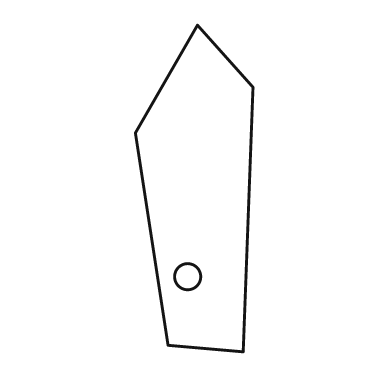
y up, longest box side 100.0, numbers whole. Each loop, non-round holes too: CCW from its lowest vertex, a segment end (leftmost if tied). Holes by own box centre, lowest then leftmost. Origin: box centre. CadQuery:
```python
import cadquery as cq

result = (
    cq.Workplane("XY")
    .moveTo(15.0, -50.0)
    .lineTo(18.0, 31.0)
    .lineTo(1.0, 50.0)
    .lineTo(-18.0, 17.0)
    .lineTo(-8.0, -48.0)
    .close()
    .moveTo(-2.0, -27.0)
    .circle(4.0)
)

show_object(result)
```